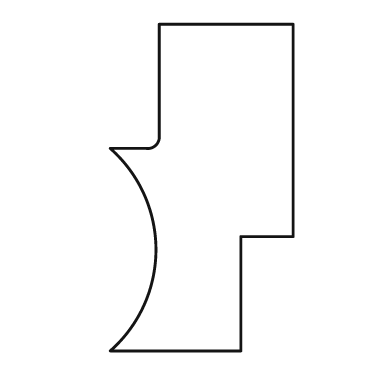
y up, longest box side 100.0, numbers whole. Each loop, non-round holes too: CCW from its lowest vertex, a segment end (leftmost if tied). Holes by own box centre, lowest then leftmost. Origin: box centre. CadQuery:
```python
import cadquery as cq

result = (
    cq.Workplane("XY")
    .moveTo(-28.0, -50.0)
    .lineTo(12.0, -50.0)
    .lineTo(12.0, -15.0)
    .lineTo(28.0, -15.0)
    .lineTo(28.0, 50.0)
    .lineTo(-13.0, 50.0)
    .lineTo(-13.0, 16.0)
    .threePointArc((-14.0, 13.0), (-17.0, 12.0))
    .lineTo(-28.0, 12.0)
    .threePointArc((-14.0, -19.0), (-28.0, -50.0))
    .close()
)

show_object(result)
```